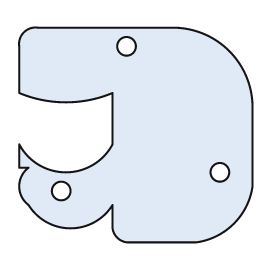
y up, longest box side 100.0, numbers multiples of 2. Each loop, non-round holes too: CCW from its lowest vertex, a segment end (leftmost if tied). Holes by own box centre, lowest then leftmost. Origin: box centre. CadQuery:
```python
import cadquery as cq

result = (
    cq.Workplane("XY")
    .moveTo(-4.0, -46.0)
    .lineTo(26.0, -46.0)
    .threePointArc((42.0, -38.0), (50.0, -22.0))
    .lineTo(50.0, 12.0)
    .threePointArc((40.0, 36.0), (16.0, 46.0))
    .lineTo(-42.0, 46.0)
    .threePointArc((-48.0, 44.0), (-50.0, 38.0))
    .lineTo(-50.0, 18.0)
    .threePointArc((-30.0, 14.0), (-10.0, 18.0))
    .lineTo(-10.0, -4.0)
    .threePointArc((-30.0, -16.0), (-50.0, -4.0))
    .lineTo(-50.0, -14.0)
    .lineTo(-46.0, -14.0)
    .threePointArc((-50.0, -22.0), (-46.0, -30.0))
    .threePointArc((-28.0, -40.0), (-10.0, -30.0))
    .lineTo(-10.0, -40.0)
    .threePointArc((-8.0, -44.0), (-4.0, -46.0))
    .close()
    .moveTo(-32.0, -24.0)
    .circle(4.0)
    .moveTo(36.0, -16.0)
    .circle(4.0)
    .moveTo(-4.0, 38.0)
    .circle(4.0)
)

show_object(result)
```